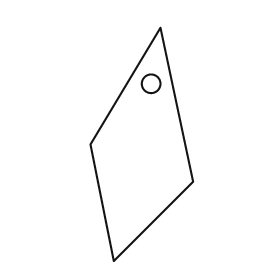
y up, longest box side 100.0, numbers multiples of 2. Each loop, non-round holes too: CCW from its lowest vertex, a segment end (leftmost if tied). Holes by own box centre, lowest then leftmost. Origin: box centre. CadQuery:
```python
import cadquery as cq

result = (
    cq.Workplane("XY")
    .moveTo(-12.0, -50.0)
    .lineTo(22.0, -16.0)
    .lineTo(8.0, 50.0)
    .lineTo(-22.0, 0.0)
    .close()
    .moveTo(4.0, 26.0)
    .circle(4.0)
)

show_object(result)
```